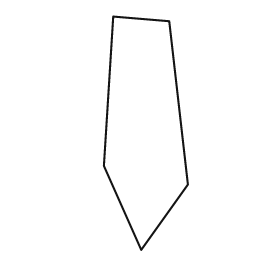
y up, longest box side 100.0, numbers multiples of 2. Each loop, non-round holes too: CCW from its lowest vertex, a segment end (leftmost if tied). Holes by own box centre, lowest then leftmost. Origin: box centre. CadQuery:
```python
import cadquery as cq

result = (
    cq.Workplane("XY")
    .moveTo(-2.0, -50.0)
    .lineTo(18.0, -22.0)
    .lineTo(10.0, 48.0)
    .lineTo(-14.0, 50.0)
    .lineTo(-18.0, -14.0)
    .close()
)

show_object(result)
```